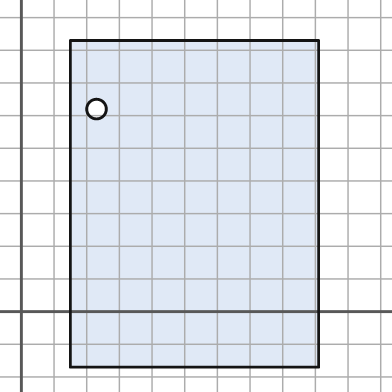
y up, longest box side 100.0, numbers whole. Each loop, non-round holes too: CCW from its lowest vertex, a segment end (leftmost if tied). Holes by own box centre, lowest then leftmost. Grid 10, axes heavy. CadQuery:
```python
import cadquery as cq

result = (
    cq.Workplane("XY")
    .moveTo(15.0, -17.0)
    .lineTo(91.0, -17.0)
    .lineTo(91.0, 83.0)
    .lineTo(15.0, 83.0)
    .close()
    .moveTo(23.0, 62.0)
    .circle(3.0)
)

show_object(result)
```